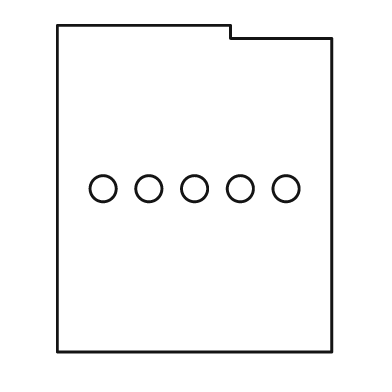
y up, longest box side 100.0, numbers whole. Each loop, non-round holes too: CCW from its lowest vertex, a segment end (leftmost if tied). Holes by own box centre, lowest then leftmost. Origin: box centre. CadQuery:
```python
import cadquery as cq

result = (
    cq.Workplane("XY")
    .moveTo(-42.0, -50.0)
    .lineTo(42.0, -50.0)
    .lineTo(42.0, 46.0)
    .lineTo(11.0, 46.0)
    .lineTo(11.0, 50.0)
    .lineTo(-42.0, 50.0)
    .close()
    .moveTo(-28.0, 0.0)
    .circle(4.0)
    .moveTo(-14.0, 0.0)
    .circle(4.0)
    .moveTo(0.0, 0.0)
    .circle(4.0)
    .moveTo(14.0, 0.0)
    .circle(4.0)
    .moveTo(28.0, 0.0)
    .circle(4.0)
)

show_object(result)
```